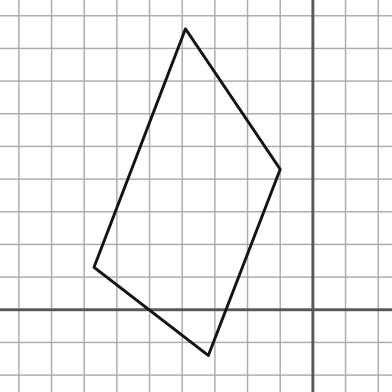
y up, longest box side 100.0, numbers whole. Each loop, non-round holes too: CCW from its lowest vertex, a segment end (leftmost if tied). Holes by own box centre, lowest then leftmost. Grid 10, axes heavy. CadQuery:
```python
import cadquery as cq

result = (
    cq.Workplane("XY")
    .moveTo(-32.0, -14.0)
    .lineTo(-10.0, 43.0)
    .lineTo(-39.0, 86.0)
    .lineTo(-67.0, 13.0)
    .close()
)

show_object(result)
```